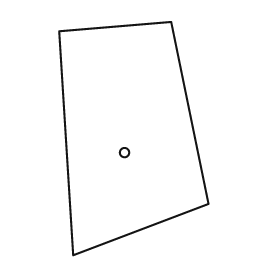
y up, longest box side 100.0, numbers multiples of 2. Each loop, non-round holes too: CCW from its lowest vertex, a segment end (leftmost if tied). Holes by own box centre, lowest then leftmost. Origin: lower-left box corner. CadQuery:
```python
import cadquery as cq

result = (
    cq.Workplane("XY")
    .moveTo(6.0, 0.0)
    .lineTo(64.0, 22.0)
    .lineTo(48.0, 100.0)
    .lineTo(0.0, 96.0)
    .close()
    .moveTo(28.0, 44.0)
    .circle(2.0)
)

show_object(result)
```